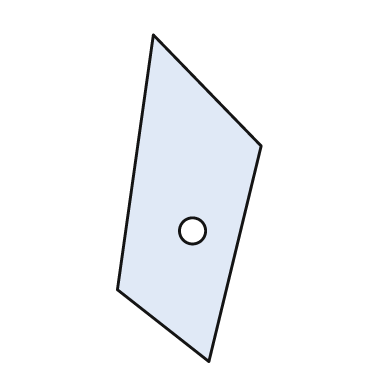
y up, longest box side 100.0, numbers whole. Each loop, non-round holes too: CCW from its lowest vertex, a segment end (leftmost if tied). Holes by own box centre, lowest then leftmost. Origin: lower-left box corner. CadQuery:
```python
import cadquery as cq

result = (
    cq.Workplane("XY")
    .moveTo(28.0, 0.0)
    .lineTo(44.0, 66.0)
    .lineTo(11.0, 100.0)
    .lineTo(0.0, 22.0)
    .close()
    .moveTo(23.0, 40.0)
    .circle(4.0)
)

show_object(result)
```